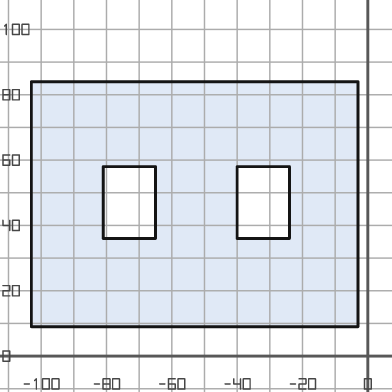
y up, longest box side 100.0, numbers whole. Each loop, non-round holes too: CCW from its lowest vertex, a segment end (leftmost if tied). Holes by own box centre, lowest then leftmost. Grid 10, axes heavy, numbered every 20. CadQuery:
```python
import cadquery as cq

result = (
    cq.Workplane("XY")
    .moveTo(-103.0, 9.0)
    .lineTo(-3.0, 9.0)
    .lineTo(-3.0, 84.0)
    .lineTo(-103.0, 84.0)
    .close()
    .moveTo(-81.0, 36.0)
    .lineTo(-65.0, 36.0)
    .lineTo(-65.0, 58.0)
    .lineTo(-81.0, 58.0)
    .close()
    .moveTo(-40.0, 36.0)
    .lineTo(-24.0, 36.0)
    .lineTo(-24.0, 58.0)
    .lineTo(-40.0, 58.0)
    .close()
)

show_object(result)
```